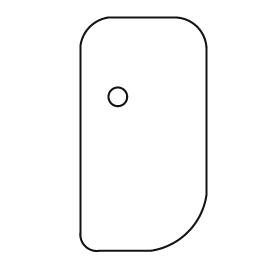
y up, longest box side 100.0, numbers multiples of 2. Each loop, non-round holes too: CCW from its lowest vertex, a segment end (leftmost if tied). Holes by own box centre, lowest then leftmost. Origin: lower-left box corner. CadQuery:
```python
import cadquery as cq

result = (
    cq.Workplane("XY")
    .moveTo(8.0, 0.0)
    .lineTo(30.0, 0.0)
    .threePointArc((46.0, 8.0), (54.0, 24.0))
    .lineTo(54.0, 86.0)
    .threePointArc((50.0, 96.0), (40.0, 100.0))
    .lineTo(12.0, 100.0)
    .threePointArc((4.0, 96.0), (0.0, 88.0))
    .lineTo(0.0, 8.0)
    .threePointArc((2.0, 2.0), (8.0, 0.0))
    .close()
    .moveTo(16.0, 66.0)
    .circle(4.0)
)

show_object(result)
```